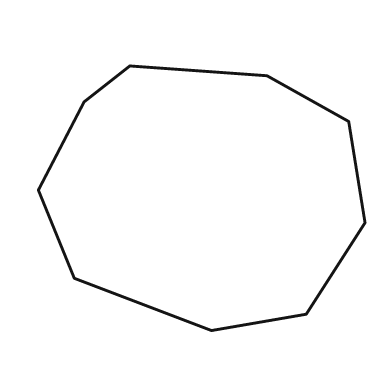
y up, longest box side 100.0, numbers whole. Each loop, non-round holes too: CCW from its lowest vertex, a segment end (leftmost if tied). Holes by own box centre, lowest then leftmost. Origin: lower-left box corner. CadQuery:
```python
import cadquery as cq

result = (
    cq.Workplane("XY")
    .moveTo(53.0, 0.0)
    .lineTo(82.0, 5.0)
    .lineTo(100.0, 33.0)
    .lineTo(95.0, 64.0)
    .lineTo(70.0, 78.0)
    .lineTo(28.0, 81.0)
    .lineTo(14.0, 70.0)
    .lineTo(0.0, 43.0)
    .lineTo(11.0, 16.0)
    .close()
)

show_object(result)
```